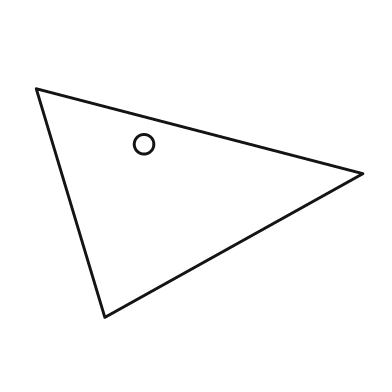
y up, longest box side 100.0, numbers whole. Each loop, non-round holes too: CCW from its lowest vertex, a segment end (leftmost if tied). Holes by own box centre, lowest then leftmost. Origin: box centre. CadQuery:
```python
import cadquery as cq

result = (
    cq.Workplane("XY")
    .moveTo(-29.0, -35.0)
    .lineTo(50.0, 9.0)
    .lineTo(-50.0, 35.0)
    .close()
    .moveTo(-17.0, 18.0)
    .circle(3.0)
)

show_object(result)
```